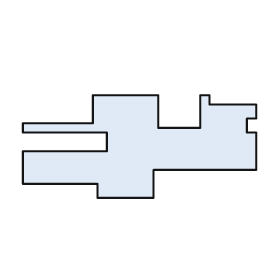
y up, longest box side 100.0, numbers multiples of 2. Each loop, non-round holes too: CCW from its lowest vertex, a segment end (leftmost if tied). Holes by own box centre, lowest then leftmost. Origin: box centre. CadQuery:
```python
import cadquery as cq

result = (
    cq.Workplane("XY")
    .moveTo(-18.0, -22.0)
    .lineTo(6.0, -22.0)
    .lineTo(6.0, -10.0)
    .lineTo(50.0, -10.0)
    .lineTo(50.0, 6.0)
    .lineTo(46.0, 6.0)
    .lineTo(46.0, 12.0)
    .lineTo(50.0, 12.0)
    .lineTo(50.0, 18.0)
    .lineTo(30.0, 18.0)
    .lineTo(30.0, 22.0)
    .lineTo(26.0, 22.0)
    .lineTo(26.0, 8.0)
    .lineTo(8.0, 8.0)
    .lineTo(8.0, 22.0)
    .lineTo(-20.0, 22.0)
    .lineTo(-20.0, 10.0)
    .lineTo(-50.0, 10.0)
    .lineTo(-50.0, 6.0)
    .lineTo(-14.0, 6.0)
    .lineTo(-14.0, -2.0)
    .lineTo(-50.0, -2.0)
    .lineTo(-50.0, -16.0)
    .lineTo(-18.0, -16.0)
    .close()
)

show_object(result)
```